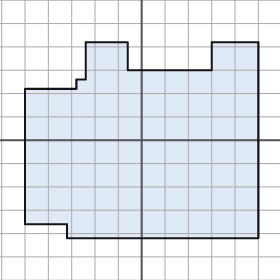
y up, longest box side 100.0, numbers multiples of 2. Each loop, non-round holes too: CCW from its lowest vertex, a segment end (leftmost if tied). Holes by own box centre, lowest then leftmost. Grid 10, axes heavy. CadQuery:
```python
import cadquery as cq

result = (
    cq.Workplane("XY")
    .moveTo(-32.0, -42.0)
    .lineTo(50.0, -42.0)
    .lineTo(50.0, 42.0)
    .lineTo(30.0, 42.0)
    .lineTo(30.0, 30.0)
    .lineTo(-6.0, 30.0)
    .lineTo(-6.0, 42.0)
    .lineTo(-24.0, 42.0)
    .lineTo(-24.0, 26.0)
    .lineTo(-28.0, 26.0)
    .lineTo(-28.0, 22.0)
    .lineTo(-50.0, 22.0)
    .lineTo(-50.0, -36.0)
    .lineTo(-32.0, -36.0)
    .close()
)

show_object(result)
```